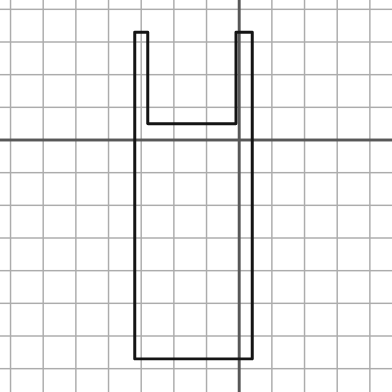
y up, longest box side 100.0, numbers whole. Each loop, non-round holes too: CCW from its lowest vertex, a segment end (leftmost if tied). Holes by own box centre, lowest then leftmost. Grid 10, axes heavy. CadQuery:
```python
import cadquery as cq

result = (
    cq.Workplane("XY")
    .moveTo(-32.0, -67.0)
    .lineTo(4.0, -67.0)
    .lineTo(4.0, 33.0)
    .lineTo(-1.0, 33.0)
    .lineTo(-1.0, 5.0)
    .lineTo(-28.0, 5.0)
    .lineTo(-28.0, 33.0)
    .lineTo(-32.0, 33.0)
    .close()
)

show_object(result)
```